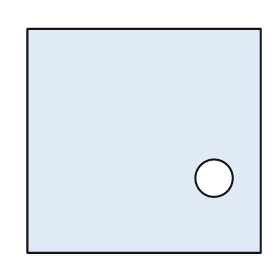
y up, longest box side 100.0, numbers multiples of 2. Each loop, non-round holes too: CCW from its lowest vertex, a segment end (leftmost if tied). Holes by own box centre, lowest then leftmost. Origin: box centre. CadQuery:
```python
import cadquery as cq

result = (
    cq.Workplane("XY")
    .moveTo(-50.0, -48.0)
    .lineTo(50.0, -48.0)
    .lineTo(50.0, 48.0)
    .lineTo(-50.0, 48.0)
    .close()
    .moveTo(30.0, -16.0)
    .circle(8.0)
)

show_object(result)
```